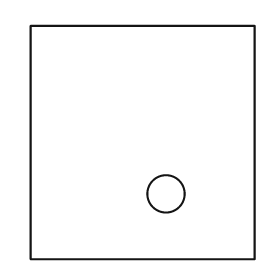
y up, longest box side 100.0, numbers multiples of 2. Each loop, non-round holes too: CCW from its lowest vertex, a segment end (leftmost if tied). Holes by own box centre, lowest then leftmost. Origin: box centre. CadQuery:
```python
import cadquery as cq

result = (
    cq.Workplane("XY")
    .moveTo(-48.0, -50.0)
    .lineTo(48.0, -50.0)
    .lineTo(48.0, 50.0)
    .lineTo(-48.0, 50.0)
    .close()
    .moveTo(10.0, -22.0)
    .circle(8.0)
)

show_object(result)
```